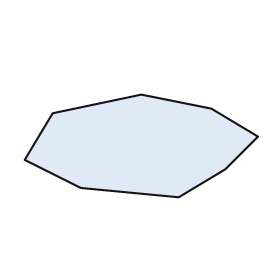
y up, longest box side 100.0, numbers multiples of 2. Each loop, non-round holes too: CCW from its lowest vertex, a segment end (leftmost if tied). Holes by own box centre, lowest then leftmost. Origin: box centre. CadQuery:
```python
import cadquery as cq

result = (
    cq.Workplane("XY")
    .moveTo(16.0, -22.0)
    .lineTo(36.0, -10.0)
    .lineTo(50.0, 4.0)
    .lineTo(30.0, 16.0)
    .lineTo(0.0, 22.0)
    .lineTo(-38.0, 14.0)
    .lineTo(-50.0, -6.0)
    .lineTo(-26.0, -18.0)
    .close()
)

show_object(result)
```